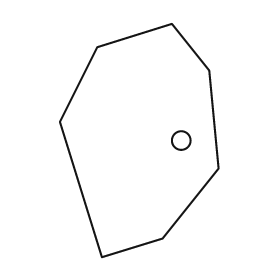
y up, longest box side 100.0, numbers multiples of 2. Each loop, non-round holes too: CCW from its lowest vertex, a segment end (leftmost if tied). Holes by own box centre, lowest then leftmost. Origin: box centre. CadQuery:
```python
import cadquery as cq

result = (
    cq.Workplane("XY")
    .moveTo(-16.0, -50.0)
    .lineTo(10.0, -42.0)
    .lineTo(34.0, -12.0)
    .lineTo(30.0, 30.0)
    .lineTo(14.0, 50.0)
    .lineTo(-18.0, 40.0)
    .lineTo(-34.0, 8.0)
    .close()
    .moveTo(18.0, 0.0)
    .circle(4.0)
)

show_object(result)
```